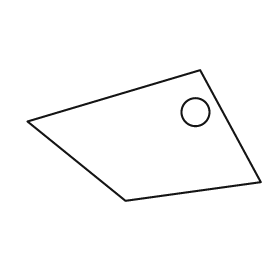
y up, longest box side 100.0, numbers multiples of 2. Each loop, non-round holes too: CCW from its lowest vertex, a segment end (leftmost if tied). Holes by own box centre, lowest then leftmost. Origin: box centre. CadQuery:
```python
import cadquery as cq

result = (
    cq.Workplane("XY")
    .moveTo(-8.0, -28.0)
    .lineTo(50.0, -20.0)
    .lineTo(24.0, 28.0)
    .lineTo(-50.0, 6.0)
    .close()
    .moveTo(22.0, 10.0)
    .circle(6.0)
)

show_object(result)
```